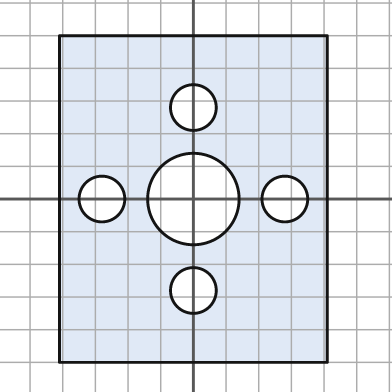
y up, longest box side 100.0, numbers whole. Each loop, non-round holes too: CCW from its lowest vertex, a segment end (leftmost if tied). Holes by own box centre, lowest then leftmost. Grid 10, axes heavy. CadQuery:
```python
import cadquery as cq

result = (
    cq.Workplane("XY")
    .moveTo(-41.0, -50.0)
    .lineTo(41.0, -50.0)
    .lineTo(41.0, 50.0)
    .lineTo(-41.0, 50.0)
    .close()
    .moveTo(0.0, -28.0)
    .circle(7.0)
    .moveTo(-28.0, 0.0)
    .circle(7.0)
    .moveTo(0.0, 0.0)
    .circle(14.0)
    .moveTo(28.0, 0.0)
    .circle(7.0)
    .moveTo(0.0, 28.0)
    .circle(7.0)
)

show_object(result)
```